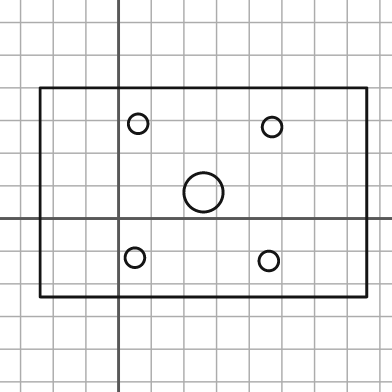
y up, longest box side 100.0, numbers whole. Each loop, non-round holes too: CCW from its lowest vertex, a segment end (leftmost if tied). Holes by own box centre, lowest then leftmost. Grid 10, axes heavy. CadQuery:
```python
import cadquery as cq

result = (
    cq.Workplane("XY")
    .moveTo(-24.0, -24.0)
    .lineTo(76.0, -24.0)
    .lineTo(76.0, 40.0)
    .lineTo(-24.0, 40.0)
    .close()
    .moveTo(46.0, -13.0)
    .circle(3.0)
    .moveTo(5.0, -12.0)
    .circle(3.0)
    .moveTo(26.0, 8.0)
    .circle(6.0)
    .moveTo(47.0, 28.0)
    .circle(3.0)
    .moveTo(6.0, 29.0)
    .circle(3.0)
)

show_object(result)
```